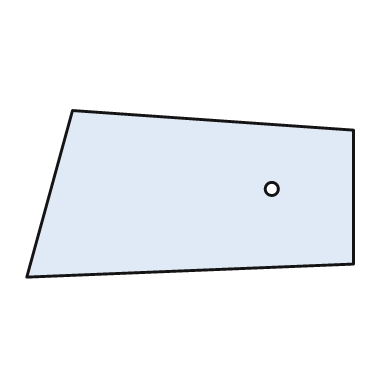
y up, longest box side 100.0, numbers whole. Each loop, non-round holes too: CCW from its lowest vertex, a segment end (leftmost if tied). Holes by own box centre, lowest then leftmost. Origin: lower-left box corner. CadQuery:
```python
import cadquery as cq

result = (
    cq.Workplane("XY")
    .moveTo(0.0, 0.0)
    .lineTo(100.0, 4.0)
    .lineTo(100.0, 45.0)
    .lineTo(14.0, 51.0)
    .close()
    .moveTo(75.0, 27.0)
    .circle(2.0)
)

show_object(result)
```